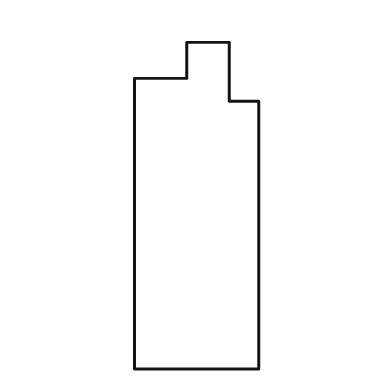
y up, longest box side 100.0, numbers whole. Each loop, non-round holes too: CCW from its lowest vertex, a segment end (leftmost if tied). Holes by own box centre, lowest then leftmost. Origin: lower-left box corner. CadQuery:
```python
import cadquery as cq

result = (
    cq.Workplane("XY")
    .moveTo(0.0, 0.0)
    .lineTo(38.0, 0.0)
    .lineTo(38.0, 82.0)
    .lineTo(29.0, 82.0)
    .lineTo(29.0, 100.0)
    .lineTo(16.0, 100.0)
    .lineTo(16.0, 89.0)
    .lineTo(0.0, 89.0)
    .close()
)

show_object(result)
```